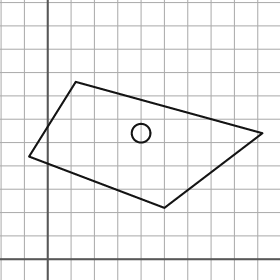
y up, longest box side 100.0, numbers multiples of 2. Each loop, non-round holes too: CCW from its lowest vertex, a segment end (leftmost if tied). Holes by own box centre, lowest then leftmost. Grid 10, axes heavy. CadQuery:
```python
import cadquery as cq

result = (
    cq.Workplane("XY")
    .moveTo(50.0, 22.0)
    .lineTo(92.0, 54.0)
    .lineTo(12.0, 76.0)
    .lineTo(-8.0, 44.0)
    .close()
    .moveTo(40.0, 54.0)
    .circle(4.0)
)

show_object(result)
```